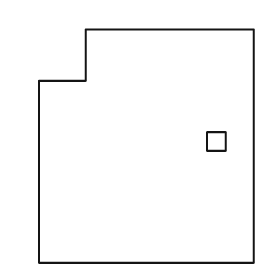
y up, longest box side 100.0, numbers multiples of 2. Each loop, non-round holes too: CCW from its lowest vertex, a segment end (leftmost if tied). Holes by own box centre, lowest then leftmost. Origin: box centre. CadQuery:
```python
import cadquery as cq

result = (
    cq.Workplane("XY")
    .moveTo(-46.0, -50.0)
    .lineTo(46.0, -50.0)
    .lineTo(46.0, 50.0)
    .lineTo(-26.0, 50.0)
    .lineTo(-26.0, 28.0)
    .lineTo(-46.0, 28.0)
    .close()
    .moveTo(26.0, -2.0)
    .lineTo(34.0, -2.0)
    .lineTo(34.0, 6.0)
    .lineTo(26.0, 6.0)
    .close()
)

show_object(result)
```